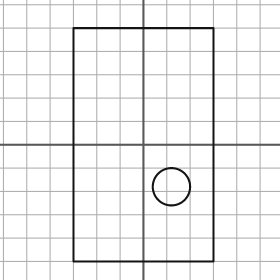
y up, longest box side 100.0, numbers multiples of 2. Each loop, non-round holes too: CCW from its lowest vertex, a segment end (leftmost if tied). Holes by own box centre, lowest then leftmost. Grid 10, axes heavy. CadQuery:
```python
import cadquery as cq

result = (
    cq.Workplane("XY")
    .moveTo(-30.0, -50.0)
    .lineTo(30.0, -50.0)
    .lineTo(30.0, 50.0)
    .lineTo(-30.0, 50.0)
    .close()
    .moveTo(12.0, -18.0)
    .circle(8.0)
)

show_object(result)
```